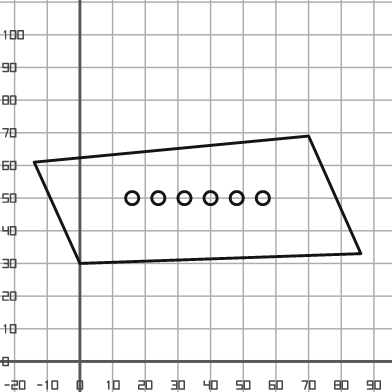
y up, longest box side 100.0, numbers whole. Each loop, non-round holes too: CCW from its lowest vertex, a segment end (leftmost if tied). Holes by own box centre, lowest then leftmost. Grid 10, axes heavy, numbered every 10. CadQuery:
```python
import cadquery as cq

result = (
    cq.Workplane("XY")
    .moveTo(0.0, 30.0)
    .lineTo(86.0, 33.0)
    .lineTo(70.0, 69.0)
    .lineTo(-14.0, 61.0)
    .close()
    .moveTo(16.0, 50.0)
    .circle(2.0)
    .moveTo(24.0, 50.0)
    .circle(2.0)
    .moveTo(32.0, 50.0)
    .circle(2.0)
    .moveTo(40.0, 50.0)
    .circle(2.0)
    .moveTo(48.0, 50.0)
    .circle(2.0)
    .moveTo(56.0, 50.0)
    .circle(2.0)
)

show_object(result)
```